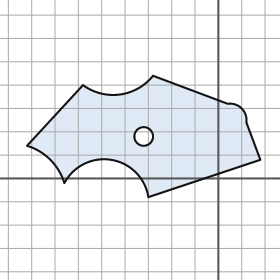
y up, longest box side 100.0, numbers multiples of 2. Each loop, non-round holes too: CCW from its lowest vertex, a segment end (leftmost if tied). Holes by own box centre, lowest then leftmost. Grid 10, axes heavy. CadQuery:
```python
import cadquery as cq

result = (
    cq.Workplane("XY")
    .moveTo(-30.0, -8.0)
    .lineTo(18.0, 8.0)
    .lineTo(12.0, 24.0)
    .threePointArc((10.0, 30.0), (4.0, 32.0))
    .lineTo(-28.0, 44.0)
    .threePointArc((-42.0, 36.0), (-58.0, 40.0))
    .lineTo(-82.0, 14.0)
    .threePointArc((-72.0, 8.0), (-66.0, -2.0))
    .threePointArc((-46.0, 8.0), (-30.0, -8.0))
    .close()
    .moveTo(-32.0, 18.0)
    .circle(4.0)
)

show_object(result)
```